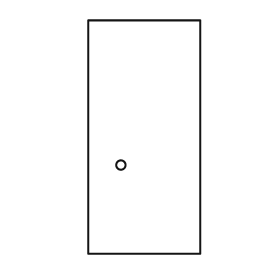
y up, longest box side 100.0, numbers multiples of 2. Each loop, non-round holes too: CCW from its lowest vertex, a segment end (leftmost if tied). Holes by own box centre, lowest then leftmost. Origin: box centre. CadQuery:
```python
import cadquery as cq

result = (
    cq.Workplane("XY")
    .moveTo(-24.0, -50.0)
    .lineTo(24.0, -50.0)
    .lineTo(24.0, 50.0)
    .lineTo(-24.0, 50.0)
    .close()
    .moveTo(-10.0, -12.0)
    .circle(2.0)
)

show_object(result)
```